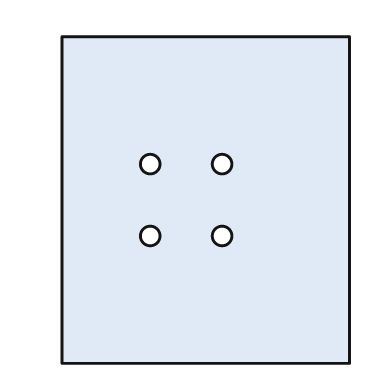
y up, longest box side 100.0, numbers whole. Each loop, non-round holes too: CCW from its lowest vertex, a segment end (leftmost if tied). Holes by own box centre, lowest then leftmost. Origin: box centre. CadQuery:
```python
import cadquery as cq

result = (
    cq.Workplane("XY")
    .moveTo(-44.0, -50.0)
    .lineTo(44.0, -50.0)
    .lineTo(44.0, 50.0)
    .lineTo(-44.0, 50.0)
    .close()
    .moveTo(-17.0, -11.0)
    .circle(3.0)
    .moveTo(5.0, -11.0)
    .circle(3.0)
    .moveTo(-17.0, 11.0)
    .circle(3.0)
    .moveTo(5.0, 11.0)
    .circle(3.0)
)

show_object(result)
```